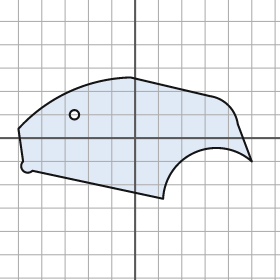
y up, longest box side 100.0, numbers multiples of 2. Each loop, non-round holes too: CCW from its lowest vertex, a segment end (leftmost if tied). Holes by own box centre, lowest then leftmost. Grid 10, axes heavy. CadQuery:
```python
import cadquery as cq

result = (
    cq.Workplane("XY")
    .moveTo(12.0, -26.0)
    .threePointArc((26.0, -6.0), (50.0, -10.0))
    .lineTo(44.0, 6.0)
    .threePointArc((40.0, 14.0), (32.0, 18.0))
    .lineTo(-2.0, 26.0)
    .threePointArc((-28.0, 20.0), (-50.0, 4.0))
    .lineTo(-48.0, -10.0)
    .threePointArc((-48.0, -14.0), (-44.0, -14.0))
    .close()
    .moveTo(-26.0, 10.0)
    .circle(2.0)
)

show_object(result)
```